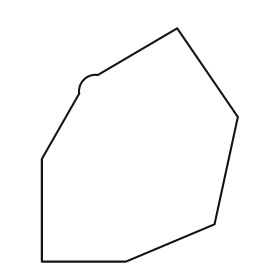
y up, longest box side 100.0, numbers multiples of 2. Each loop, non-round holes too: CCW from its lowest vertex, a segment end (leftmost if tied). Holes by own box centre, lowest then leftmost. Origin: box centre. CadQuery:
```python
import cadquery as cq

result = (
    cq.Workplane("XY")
    .moveTo(-42.0, -50.0)
    .lineTo(-6.0, -50.0)
    .lineTo(32.0, -34.0)
    .lineTo(42.0, 12.0)
    .lineTo(16.0, 50.0)
    .lineTo(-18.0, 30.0)
    .threePointArc((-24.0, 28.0), (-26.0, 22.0))
    .lineTo(-42.0, -6.0)
    .close()
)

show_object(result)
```